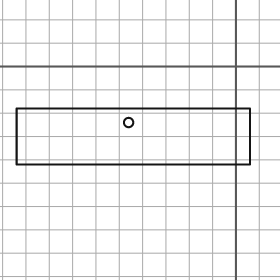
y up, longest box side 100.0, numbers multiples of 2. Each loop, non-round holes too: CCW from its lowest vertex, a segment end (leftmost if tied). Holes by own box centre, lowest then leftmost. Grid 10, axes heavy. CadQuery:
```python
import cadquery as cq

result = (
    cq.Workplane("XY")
    .moveTo(-94.0, -42.0)
    .lineTo(6.0, -42.0)
    .lineTo(6.0, -18.0)
    .lineTo(-94.0, -18.0)
    .close()
    .moveTo(-46.0, -24.0)
    .circle(2.0)
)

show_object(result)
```